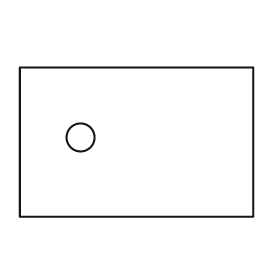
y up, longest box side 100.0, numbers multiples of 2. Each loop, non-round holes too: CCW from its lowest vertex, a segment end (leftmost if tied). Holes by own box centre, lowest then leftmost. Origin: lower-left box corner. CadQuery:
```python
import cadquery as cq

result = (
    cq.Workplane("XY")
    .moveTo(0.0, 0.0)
    .lineTo(100.0, 0.0)
    .lineTo(100.0, 64.0)
    .lineTo(0.0, 64.0)
    .close()
    .moveTo(26.0, 34.0)
    .circle(6.0)
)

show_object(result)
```